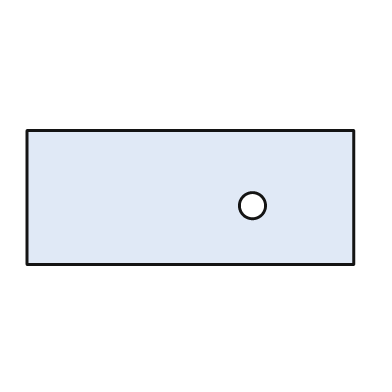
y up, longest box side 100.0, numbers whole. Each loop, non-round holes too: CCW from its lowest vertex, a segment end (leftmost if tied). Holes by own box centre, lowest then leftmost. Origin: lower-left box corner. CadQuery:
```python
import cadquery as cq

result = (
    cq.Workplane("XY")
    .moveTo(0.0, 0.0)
    .lineTo(100.0, 0.0)
    .lineTo(100.0, 41.0)
    .lineTo(0.0, 41.0)
    .close()
    .moveTo(69.0, 18.0)
    .circle(4.0)
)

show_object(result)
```